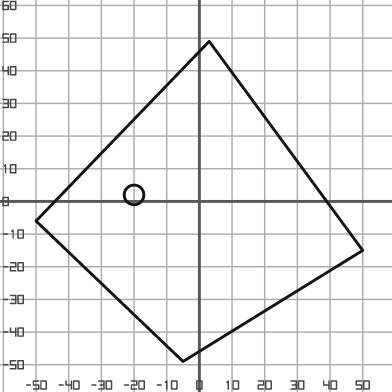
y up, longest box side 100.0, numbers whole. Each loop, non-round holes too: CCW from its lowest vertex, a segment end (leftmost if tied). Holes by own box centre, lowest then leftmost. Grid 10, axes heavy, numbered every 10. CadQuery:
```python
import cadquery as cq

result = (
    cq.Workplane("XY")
    .moveTo(-5.0, -49.0)
    .lineTo(50.0, -15.0)
    .lineTo(3.0, 49.0)
    .lineTo(-50.0, -6.0)
    .close()
    .moveTo(-20.0, 2.0)
    .circle(3.0)
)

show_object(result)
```